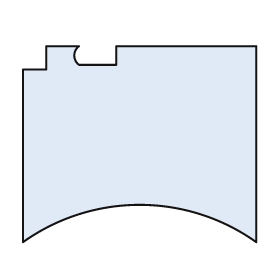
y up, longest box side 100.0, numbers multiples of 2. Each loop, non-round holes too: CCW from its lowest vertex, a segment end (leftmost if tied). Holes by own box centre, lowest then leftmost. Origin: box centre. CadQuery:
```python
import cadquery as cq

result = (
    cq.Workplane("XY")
    .moveTo(-50.0, -42.0)
    .threePointArc((0.0, -26.0), (50.0, -42.0))
    .lineTo(50.0, 42.0)
    .lineTo(-10.0, 42.0)
    .lineTo(-10.0, 34.0)
    .lineTo(-26.0, 34.0)
    .threePointArc((-28.0, 38.0), (-26.0, 42.0))
    .lineTo(-40.0, 42.0)
    .lineTo(-40.0, 32.0)
    .lineTo(-50.0, 32.0)
    .close()
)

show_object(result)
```